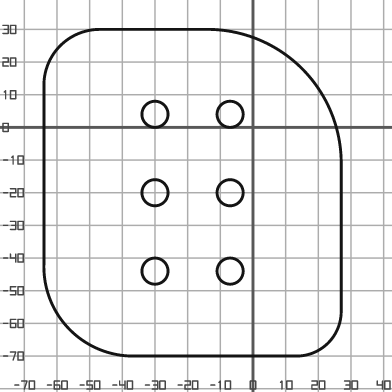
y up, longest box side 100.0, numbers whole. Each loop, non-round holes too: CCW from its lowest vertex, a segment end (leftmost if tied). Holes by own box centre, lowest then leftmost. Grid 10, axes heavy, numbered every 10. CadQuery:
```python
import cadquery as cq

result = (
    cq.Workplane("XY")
    .moveTo(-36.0, -70.0)
    .lineTo(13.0, -70.0)
    .threePointArc((23.0, -66.0), (27.0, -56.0))
    .lineTo(27.0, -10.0)
    .threePointArc((15.0, 18.0), (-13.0, 30.0))
    .lineTo(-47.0, 30.0)
    .threePointArc((-59.0, 25.0), (-64.0, 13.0))
    .lineTo(-64.0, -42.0)
    .threePointArc((-56.0, -62.0), (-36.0, -70.0))
    .close()
    .moveTo(-30.0, -44.0)
    .circle(4.0)
    .moveTo(-7.0, -44.0)
    .circle(4.0)
    .moveTo(-30.0, -20.0)
    .circle(4.0)
    .moveTo(-7.0, -20.0)
    .circle(4.0)
    .moveTo(-30.0, 4.0)
    .circle(4.0)
    .moveTo(-7.0, 4.0)
    .circle(4.0)
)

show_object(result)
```